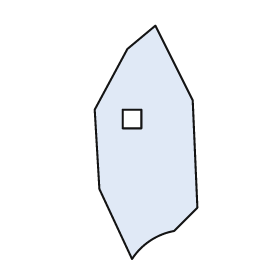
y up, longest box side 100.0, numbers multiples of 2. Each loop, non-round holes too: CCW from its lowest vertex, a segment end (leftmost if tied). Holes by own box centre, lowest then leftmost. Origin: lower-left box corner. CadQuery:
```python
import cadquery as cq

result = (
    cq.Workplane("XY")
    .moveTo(16.0, 0.0)
    .threePointArc((24.0, 8.0), (34.0, 12.0))
    .lineTo(44.0, 22.0)
    .lineTo(42.0, 68.0)
    .lineTo(26.0, 100.0)
    .lineTo(14.0, 90.0)
    .lineTo(0.0, 64.0)
    .lineTo(2.0, 30.0)
    .close()
    .moveTo(12.0, 56.0)
    .lineTo(20.0, 56.0)
    .lineTo(20.0, 64.0)
    .lineTo(12.0, 64.0)
    .close()
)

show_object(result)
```